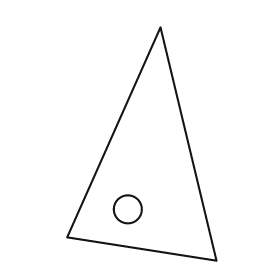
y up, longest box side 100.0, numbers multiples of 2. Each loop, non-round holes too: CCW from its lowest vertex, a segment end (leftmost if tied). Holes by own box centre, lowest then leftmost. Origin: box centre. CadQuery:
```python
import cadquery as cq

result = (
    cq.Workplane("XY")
    .moveTo(32.0, -50.0)
    .lineTo(8.0, 50.0)
    .lineTo(-32.0, -40.0)
    .close()
    .moveTo(-6.0, -28.0)
    .circle(6.0)
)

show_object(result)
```